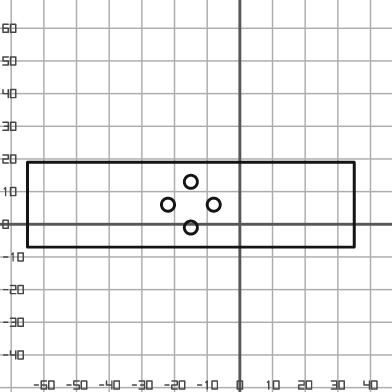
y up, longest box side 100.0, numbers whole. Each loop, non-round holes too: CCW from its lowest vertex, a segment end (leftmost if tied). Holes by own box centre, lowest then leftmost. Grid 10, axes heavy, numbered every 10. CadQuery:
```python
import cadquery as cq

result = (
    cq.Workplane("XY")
    .moveTo(-65.0, -7.0)
    .lineTo(35.0, -7.0)
    .lineTo(35.0, 19.0)
    .lineTo(-65.0, 19.0)
    .close()
    .moveTo(-15.0, -1.0)
    .circle(2.0)
    .moveTo(-22.0, 6.0)
    .circle(2.0)
    .moveTo(-8.0, 6.0)
    .circle(2.0)
    .moveTo(-15.0, 13.0)
    .circle(2.0)
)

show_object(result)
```